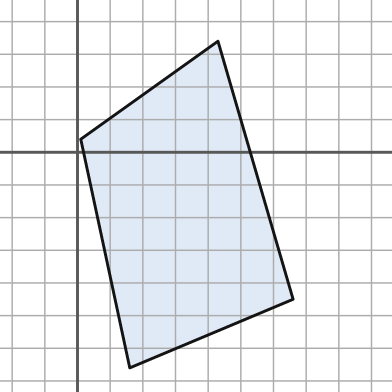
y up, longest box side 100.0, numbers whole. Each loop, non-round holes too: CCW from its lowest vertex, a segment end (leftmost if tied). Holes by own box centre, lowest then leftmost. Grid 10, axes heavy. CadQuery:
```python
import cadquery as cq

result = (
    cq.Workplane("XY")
    .moveTo(16.0, -66.0)
    .lineTo(66.0, -45.0)
    .lineTo(43.0, 34.0)
    .lineTo(1.0, 4.0)
    .close()
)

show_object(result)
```